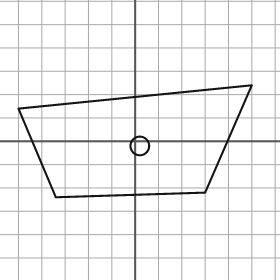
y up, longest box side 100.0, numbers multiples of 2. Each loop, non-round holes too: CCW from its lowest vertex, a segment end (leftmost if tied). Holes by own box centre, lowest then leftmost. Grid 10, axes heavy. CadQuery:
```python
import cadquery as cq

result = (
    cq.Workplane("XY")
    .moveTo(-34.0, -24.0)
    .lineTo(30.0, -22.0)
    .lineTo(50.0, 24.0)
    .lineTo(-50.0, 14.0)
    .close()
    .moveTo(2.0, -2.0)
    .circle(4.0)
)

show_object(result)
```